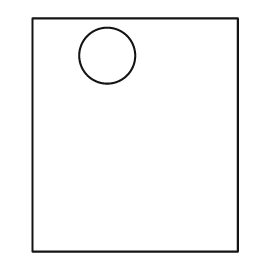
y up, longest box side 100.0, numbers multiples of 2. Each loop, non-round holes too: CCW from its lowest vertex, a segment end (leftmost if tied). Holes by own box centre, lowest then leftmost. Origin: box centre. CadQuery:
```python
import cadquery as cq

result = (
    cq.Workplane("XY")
    .moveTo(-44.0, -50.0)
    .lineTo(44.0, -50.0)
    .lineTo(44.0, 50.0)
    .lineTo(-44.0, 50.0)
    .close()
    .moveTo(-12.0, 34.0)
    .circle(12.0)
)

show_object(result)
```